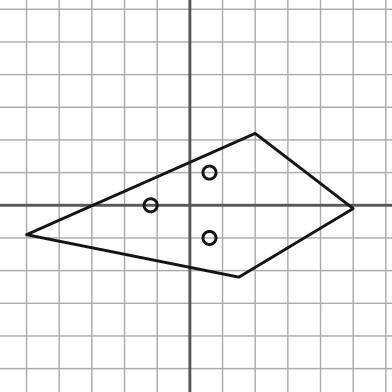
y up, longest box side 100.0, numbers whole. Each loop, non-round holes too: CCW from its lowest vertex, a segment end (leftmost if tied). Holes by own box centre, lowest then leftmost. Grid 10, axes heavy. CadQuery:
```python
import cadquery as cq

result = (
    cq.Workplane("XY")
    .moveTo(15.0, -22.0)
    .lineTo(50.0, -1.0)
    .lineTo(20.0, 22.0)
    .lineTo(-50.0, -9.0)
    .close()
    .moveTo(6.0, -10.0)
    .circle(2.0)
    .moveTo(-12.0, 0.0)
    .circle(2.0)
    .moveTo(6.0, 10.0)
    .circle(2.0)
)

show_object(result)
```